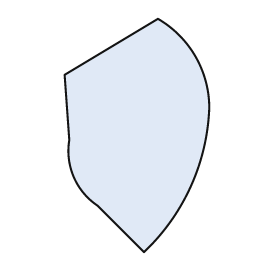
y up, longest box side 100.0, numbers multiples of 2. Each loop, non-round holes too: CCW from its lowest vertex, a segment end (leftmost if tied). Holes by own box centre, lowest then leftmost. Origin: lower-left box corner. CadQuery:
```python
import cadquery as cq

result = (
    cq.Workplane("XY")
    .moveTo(34.0, 0.0)
    .threePointArc((54.0, 28.0), (62.0, 62.0))
    .threePointArc((56.0, 84.0), (40.0, 100.0))
    .lineTo(0.0, 76.0)
    .lineTo(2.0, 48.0)
    .threePointArc((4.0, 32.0), (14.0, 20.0))
    .close()
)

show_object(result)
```